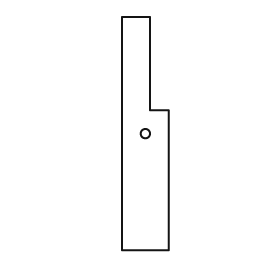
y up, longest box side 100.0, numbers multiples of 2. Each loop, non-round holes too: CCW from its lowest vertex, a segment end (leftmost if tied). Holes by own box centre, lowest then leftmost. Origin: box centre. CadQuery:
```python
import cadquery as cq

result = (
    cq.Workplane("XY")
    .moveTo(-10.0, -50.0)
    .lineTo(10.0, -50.0)
    .lineTo(10.0, 10.0)
    .lineTo(2.0, 10.0)
    .lineTo(2.0, 50.0)
    .lineTo(-10.0, 50.0)
    .close()
    .moveTo(0.0, 0.0)
    .circle(2.0)
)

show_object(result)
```